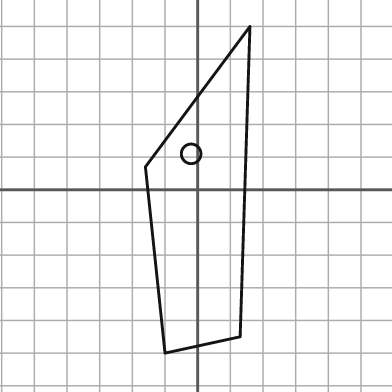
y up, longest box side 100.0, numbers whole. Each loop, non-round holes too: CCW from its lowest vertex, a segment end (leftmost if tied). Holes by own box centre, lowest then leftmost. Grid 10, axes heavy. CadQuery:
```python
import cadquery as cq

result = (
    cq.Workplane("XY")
    .moveTo(-10.0, -50.0)
    .lineTo(13.0, -45.0)
    .lineTo(16.0, 50.0)
    .lineTo(-16.0, 7.0)
    .close()
    .moveTo(-2.0, 11.0)
    .circle(3.0)
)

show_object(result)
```